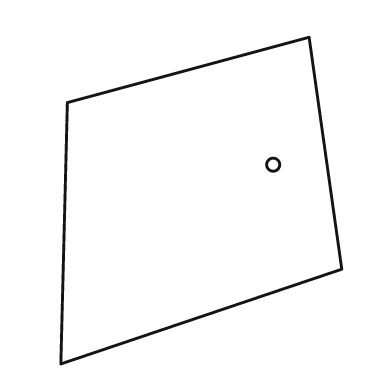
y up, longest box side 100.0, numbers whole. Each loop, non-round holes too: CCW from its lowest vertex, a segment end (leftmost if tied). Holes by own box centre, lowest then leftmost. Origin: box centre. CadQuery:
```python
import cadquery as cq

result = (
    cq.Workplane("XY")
    .moveTo(-43.0, -50.0)
    .lineTo(43.0, -21.0)
    .lineTo(33.0, 50.0)
    .lineTo(-41.0, 30.0)
    .close()
    .moveTo(22.0, 11.0)
    .circle(2.0)
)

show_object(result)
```